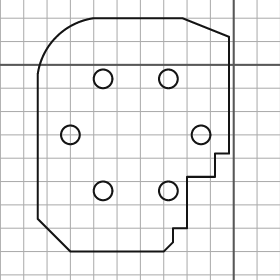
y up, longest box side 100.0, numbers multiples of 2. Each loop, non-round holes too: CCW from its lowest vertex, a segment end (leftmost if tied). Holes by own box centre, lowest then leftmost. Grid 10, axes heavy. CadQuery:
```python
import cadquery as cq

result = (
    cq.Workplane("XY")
    .moveTo(-70.0, -80.0)
    .lineTo(-30.0, -80.0)
    .lineTo(-26.0, -76.0)
    .lineTo(-26.0, -70.0)
    .lineTo(-20.0, -70.0)
    .lineTo(-20.0, -48.0)
    .lineTo(-8.0, -48.0)
    .lineTo(-8.0, -38.0)
    .lineTo(-2.0, -38.0)
    .lineTo(-2.0, 12.0)
    .lineTo(-22.0, 20.0)
    .lineTo(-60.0, 20.0)
    .threePointArc((-76.0, 12.0), (-84.0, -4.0))
    .lineTo(-84.0, -66.0)
    .close()
    .moveTo(-56.0, -54.0)
    .circle(4.0)
    .moveTo(-28.0, -54.0)
    .circle(4.0)
    .moveTo(-70.0, -30.0)
    .circle(4.0)
    .moveTo(-14.0, -30.0)
    .circle(4.0)
    .moveTo(-56.0, -6.0)
    .circle(4.0)
    .moveTo(-28.0, -6.0)
    .circle(4.0)
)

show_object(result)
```